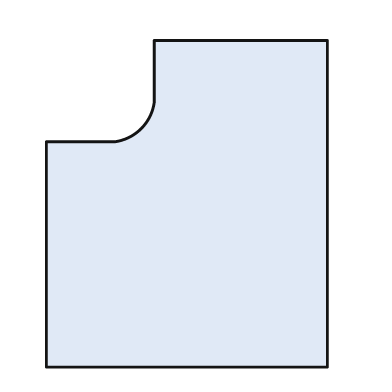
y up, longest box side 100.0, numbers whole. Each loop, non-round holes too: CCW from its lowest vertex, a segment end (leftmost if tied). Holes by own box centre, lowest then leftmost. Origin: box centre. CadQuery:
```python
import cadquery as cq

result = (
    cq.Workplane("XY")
    .moveTo(-43.0, -50.0)
    .lineTo(43.0, -50.0)
    .lineTo(43.0, 50.0)
    .lineTo(-10.0, 50.0)
    .lineTo(-10.0, 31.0)
    .threePointArc((-14.0, 23.0), (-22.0, 19.0))
    .lineTo(-43.0, 19.0)
    .close()
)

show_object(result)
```